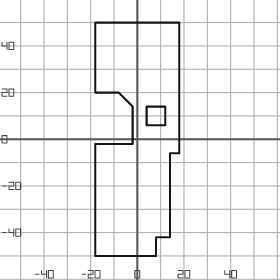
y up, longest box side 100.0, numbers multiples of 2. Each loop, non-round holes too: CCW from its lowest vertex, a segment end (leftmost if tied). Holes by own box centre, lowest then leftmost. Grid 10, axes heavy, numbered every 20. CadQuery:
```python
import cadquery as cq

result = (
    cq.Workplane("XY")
    .moveTo(-18.0, -50.0)
    .lineTo(8.0, -50.0)
    .lineTo(8.0, -42.0)
    .lineTo(14.0, -42.0)
    .lineTo(14.0, -6.0)
    .lineTo(18.0, -6.0)
    .lineTo(18.0, 50.0)
    .lineTo(-18.0, 50.0)
    .lineTo(-18.0, 20.0)
    .lineTo(-8.0, 20.0)
    .lineTo(-2.0, 14.0)
    .lineTo(-2.0, -2.0)
    .lineTo(-18.0, -2.0)
    .close()
    .moveTo(4.0, 6.0)
    .lineTo(12.0, 6.0)
    .lineTo(12.0, 14.0)
    .lineTo(4.0, 14.0)
    .close()
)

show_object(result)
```